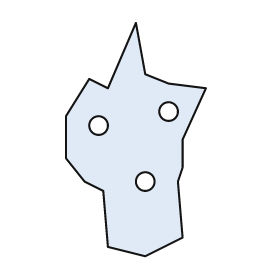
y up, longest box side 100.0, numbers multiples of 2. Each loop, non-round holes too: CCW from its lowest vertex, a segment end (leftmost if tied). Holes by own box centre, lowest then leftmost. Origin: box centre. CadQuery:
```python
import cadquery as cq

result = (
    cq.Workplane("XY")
    .moveTo(4.0, -50.0)
    .lineTo(20.0, -42.0)
    .lineTo(18.0, -18.0)
    .lineTo(20.0, -12.0)
    .lineTo(20.0, 0.0)
    .lineTo(30.0, 22.0)
    .lineTo(14.0, 24.0)
    .lineTo(4.0, 28.0)
    .lineTo(0.0, 50.0)
    .lineTo(-12.0, 22.0)
    .lineTo(-20.0, 26.0)
    .lineTo(-30.0, 10.0)
    .lineTo(-30.0, -8.0)
    .lineTo(-22.0, -18.0)
    .lineTo(-14.0, -22.0)
    .lineTo(-12.0, -46.0)
    .close()
    .moveTo(4.0, -18.0)
    .circle(4.0)
    .moveTo(-16.0, 6.0)
    .circle(4.0)
    .moveTo(14.0, 12.0)
    .circle(4.0)
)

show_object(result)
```